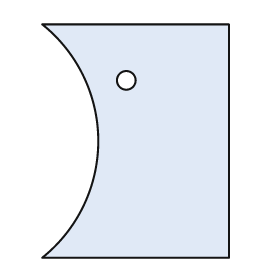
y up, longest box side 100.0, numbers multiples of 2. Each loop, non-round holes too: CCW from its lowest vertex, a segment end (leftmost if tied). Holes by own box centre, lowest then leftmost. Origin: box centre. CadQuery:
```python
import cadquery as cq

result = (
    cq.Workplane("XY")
    .moveTo(-40.0, -50.0)
    .lineTo(40.0, -50.0)
    .lineTo(40.0, 50.0)
    .lineTo(-40.0, 50.0)
    .threePointArc((-16.0, 0.0), (-40.0, -50.0))
    .close()
    .moveTo(-4.0, 26.0)
    .circle(4.0)
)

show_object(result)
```